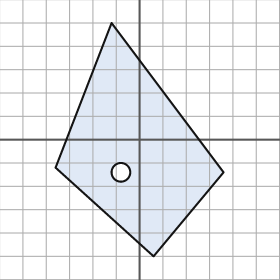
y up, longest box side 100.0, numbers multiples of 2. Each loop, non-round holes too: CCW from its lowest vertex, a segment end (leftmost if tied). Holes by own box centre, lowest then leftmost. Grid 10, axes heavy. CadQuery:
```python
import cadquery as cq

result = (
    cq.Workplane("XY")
    .moveTo(6.0, -50.0)
    .lineTo(36.0, -14.0)
    .lineTo(-12.0, 50.0)
    .lineTo(-36.0, -12.0)
    .close()
    .moveTo(-8.0, -14.0)
    .circle(4.0)
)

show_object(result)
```